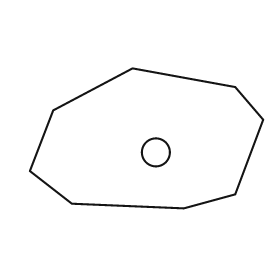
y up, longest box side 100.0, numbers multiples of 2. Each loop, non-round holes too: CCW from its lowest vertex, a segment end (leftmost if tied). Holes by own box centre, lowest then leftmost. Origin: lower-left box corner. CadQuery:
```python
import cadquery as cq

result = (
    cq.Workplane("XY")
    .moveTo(66.0, 0.0)
    .lineTo(88.0, 6.0)
    .lineTo(100.0, 38.0)
    .lineTo(88.0, 52.0)
    .lineTo(44.0, 60.0)
    .lineTo(10.0, 42.0)
    .lineTo(0.0, 16.0)
    .lineTo(18.0, 2.0)
    .close()
    .moveTo(54.0, 24.0)
    .circle(6.0)
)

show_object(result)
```